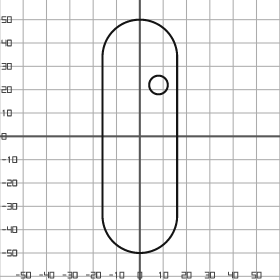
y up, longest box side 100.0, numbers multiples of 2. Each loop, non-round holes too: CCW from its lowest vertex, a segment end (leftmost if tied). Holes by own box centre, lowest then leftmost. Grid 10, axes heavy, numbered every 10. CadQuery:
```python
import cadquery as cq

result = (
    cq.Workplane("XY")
    .moveTo(-16.0, -34.0)
    .threePointArc((0.0, -50.0), (16.0, -34.0))
    .lineTo(16.0, 34.0)
    .threePointArc((0.0, 50.0), (-16.0, 34.0))
    .close()
    .moveTo(8.0, 22.0)
    .circle(4.0)
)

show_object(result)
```